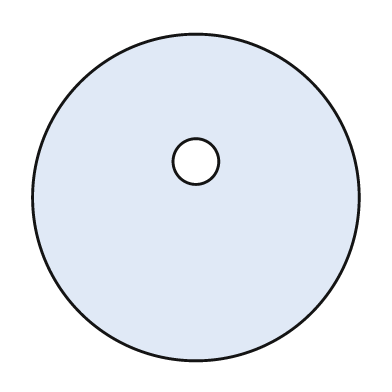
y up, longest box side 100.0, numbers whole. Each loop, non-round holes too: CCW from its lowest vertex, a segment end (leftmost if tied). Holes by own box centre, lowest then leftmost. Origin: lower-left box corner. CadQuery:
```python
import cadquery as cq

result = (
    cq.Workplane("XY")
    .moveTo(50.0, 50.0)
    .circle(50.0)
    .moveTo(50.0, 61.0)
    .circle(7.0)
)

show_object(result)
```